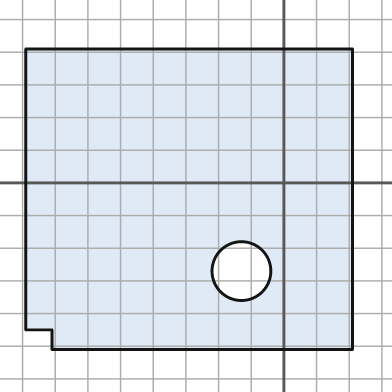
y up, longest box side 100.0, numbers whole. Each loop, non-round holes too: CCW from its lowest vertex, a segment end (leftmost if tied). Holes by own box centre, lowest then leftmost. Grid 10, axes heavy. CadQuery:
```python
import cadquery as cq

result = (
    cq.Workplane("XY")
    .moveTo(-71.0, -51.0)
    .lineTo(21.0, -51.0)
    .lineTo(21.0, 41.0)
    .lineTo(-79.0, 41.0)
    .lineTo(-79.0, -45.0)
    .lineTo(-71.0, -45.0)
    .close()
    .moveTo(-13.0, -27.0)
    .circle(9.0)
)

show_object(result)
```